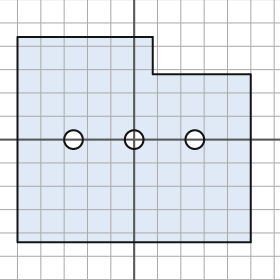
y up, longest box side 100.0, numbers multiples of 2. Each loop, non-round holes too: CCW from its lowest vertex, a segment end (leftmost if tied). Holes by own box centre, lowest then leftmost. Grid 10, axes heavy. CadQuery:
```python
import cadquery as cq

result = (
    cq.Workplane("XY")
    .moveTo(-50.0, -44.0)
    .lineTo(50.0, -44.0)
    .lineTo(50.0, 28.0)
    .lineTo(8.0, 28.0)
    .lineTo(8.0, 44.0)
    .lineTo(-50.0, 44.0)
    .close()
    .moveTo(-26.0, 0.0)
    .circle(4.0)
    .moveTo(0.0, 0.0)
    .circle(4.0)
    .moveTo(26.0, 0.0)
    .circle(4.0)
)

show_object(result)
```